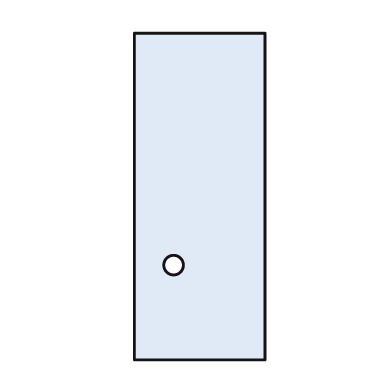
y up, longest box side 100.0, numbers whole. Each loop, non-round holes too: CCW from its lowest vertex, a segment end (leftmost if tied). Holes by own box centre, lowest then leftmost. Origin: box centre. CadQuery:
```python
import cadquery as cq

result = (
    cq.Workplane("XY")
    .moveTo(-20.0, -50.0)
    .lineTo(20.0, -50.0)
    .lineTo(20.0, 50.0)
    .lineTo(-20.0, 50.0)
    .close()
    .moveTo(-8.0, -21.0)
    .circle(3.0)
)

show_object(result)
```